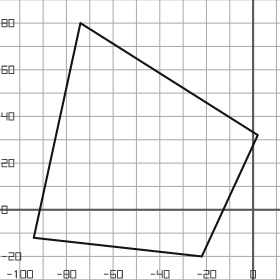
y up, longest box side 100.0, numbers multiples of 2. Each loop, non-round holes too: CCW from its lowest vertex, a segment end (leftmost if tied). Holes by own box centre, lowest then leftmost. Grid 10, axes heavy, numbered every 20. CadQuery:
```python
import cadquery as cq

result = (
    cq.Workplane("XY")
    .moveTo(-22.0, -20.0)
    .lineTo(2.0, 32.0)
    .lineTo(-74.0, 80.0)
    .lineTo(-94.0, -12.0)
    .close()
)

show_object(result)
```